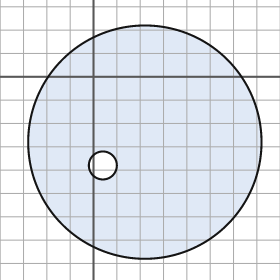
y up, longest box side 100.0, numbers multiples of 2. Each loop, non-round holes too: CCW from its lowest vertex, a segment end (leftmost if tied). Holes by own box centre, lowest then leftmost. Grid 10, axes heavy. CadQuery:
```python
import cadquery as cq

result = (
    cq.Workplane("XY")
    .moveTo(22.0, -28.0)
    .circle(50.0)
    .moveTo(4.0, -38.0)
    .circle(6.0)
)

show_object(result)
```